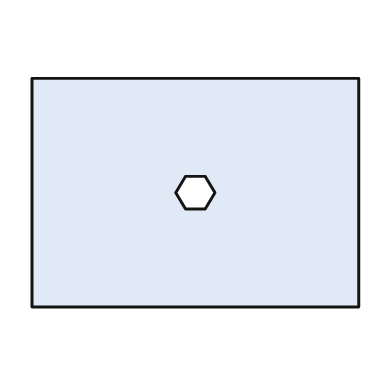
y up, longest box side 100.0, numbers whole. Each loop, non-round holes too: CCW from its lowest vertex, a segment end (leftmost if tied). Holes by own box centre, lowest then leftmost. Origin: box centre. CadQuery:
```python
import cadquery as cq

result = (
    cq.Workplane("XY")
    .moveTo(-50.0, -35.0)
    .lineTo(50.0, -35.0)
    .lineTo(50.0, 35.0)
    .lineTo(-50.0, 35.0)
    .close()
    .moveTo(-3.0, -5.0)
    .lineTo(3.0, -5.0)
    .lineTo(6.0, 0.0)
    .lineTo(3.0, 5.0)
    .lineTo(-3.0, 5.0)
    .lineTo(-6.0, 0.0)
    .close()
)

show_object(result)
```